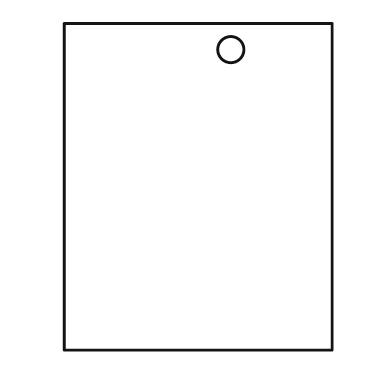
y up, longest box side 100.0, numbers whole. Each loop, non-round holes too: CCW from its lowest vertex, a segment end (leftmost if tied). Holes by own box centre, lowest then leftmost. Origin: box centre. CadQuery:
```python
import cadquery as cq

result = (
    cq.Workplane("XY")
    .moveTo(-41.0, -50.0)
    .lineTo(41.0, -50.0)
    .lineTo(41.0, 50.0)
    .lineTo(-41.0, 50.0)
    .close()
    .moveTo(10.0, 42.0)
    .circle(4.0)
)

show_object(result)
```